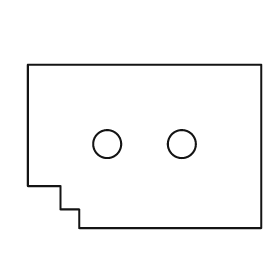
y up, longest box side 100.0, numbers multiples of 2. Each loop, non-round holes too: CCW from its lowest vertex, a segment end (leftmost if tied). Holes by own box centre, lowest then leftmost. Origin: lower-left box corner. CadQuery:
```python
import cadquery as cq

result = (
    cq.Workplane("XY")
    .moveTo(22.0, 0.0)
    .lineTo(100.0, 0.0)
    .lineTo(100.0, 70.0)
    .lineTo(0.0, 70.0)
    .lineTo(0.0, 18.0)
    .lineTo(14.0, 18.0)
    .lineTo(14.0, 8.0)
    .lineTo(22.0, 8.0)
    .close()
    .moveTo(34.0, 36.0)
    .circle(6.0)
    .moveTo(66.0, 36.0)
    .circle(6.0)
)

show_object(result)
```